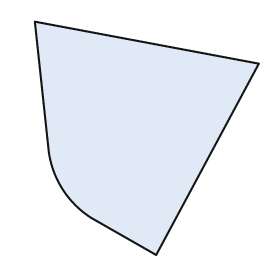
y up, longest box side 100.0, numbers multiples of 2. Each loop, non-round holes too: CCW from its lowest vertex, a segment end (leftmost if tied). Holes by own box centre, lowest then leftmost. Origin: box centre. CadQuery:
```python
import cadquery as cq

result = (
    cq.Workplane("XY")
    .moveTo(4.0, -50.0)
    .lineTo(48.0, 32.0)
    .lineTo(-48.0, 50.0)
    .lineTo(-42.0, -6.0)
    .threePointArc((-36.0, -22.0), (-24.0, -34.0))
    .close()
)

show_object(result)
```